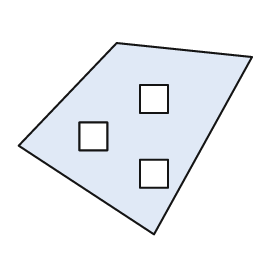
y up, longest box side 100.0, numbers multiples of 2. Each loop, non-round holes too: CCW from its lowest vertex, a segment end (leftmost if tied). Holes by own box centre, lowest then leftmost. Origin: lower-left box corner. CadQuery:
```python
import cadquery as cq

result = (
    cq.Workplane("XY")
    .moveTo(58.0, 0.0)
    .lineTo(100.0, 76.0)
    .lineTo(42.0, 82.0)
    .lineTo(0.0, 38.0)
    .close()
    .moveTo(52.0, 20.0)
    .lineTo(64.0, 20.0)
    .lineTo(64.0, 32.0)
    .lineTo(52.0, 32.0)
    .close()
    .moveTo(26.0, 36.0)
    .lineTo(38.0, 36.0)
    .lineTo(38.0, 48.0)
    .lineTo(26.0, 48.0)
    .close()
    .moveTo(52.0, 52.0)
    .lineTo(64.0, 52.0)
    .lineTo(64.0, 64.0)
    .lineTo(52.0, 64.0)
    .close()
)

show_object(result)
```